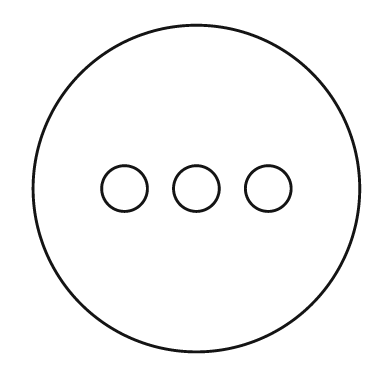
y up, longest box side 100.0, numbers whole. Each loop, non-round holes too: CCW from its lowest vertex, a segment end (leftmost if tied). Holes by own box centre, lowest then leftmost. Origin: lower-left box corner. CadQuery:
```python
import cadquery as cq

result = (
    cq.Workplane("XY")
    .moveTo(50.0, 50.0)
    .circle(50.0)
    .moveTo(28.0, 50.0)
    .circle(7.0)
    .moveTo(50.0, 50.0)
    .circle(7.0)
    .moveTo(72.0, 50.0)
    .circle(7.0)
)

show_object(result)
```